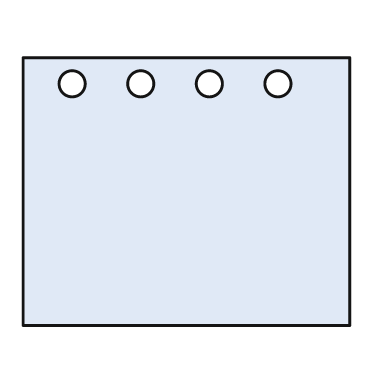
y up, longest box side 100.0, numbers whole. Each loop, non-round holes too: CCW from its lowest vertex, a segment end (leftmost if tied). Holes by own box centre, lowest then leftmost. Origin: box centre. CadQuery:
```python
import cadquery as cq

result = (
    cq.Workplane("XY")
    .moveTo(-50.0, -41.0)
    .lineTo(50.0, -41.0)
    .lineTo(50.0, 41.0)
    .lineTo(-50.0, 41.0)
    .close()
    .moveTo(-35.0, 33.0)
    .circle(4.0)
    .moveTo(-14.0, 33.0)
    .circle(4.0)
    .moveTo(7.0, 33.0)
    .circle(4.0)
    .moveTo(28.0, 33.0)
    .circle(4.0)
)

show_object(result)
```